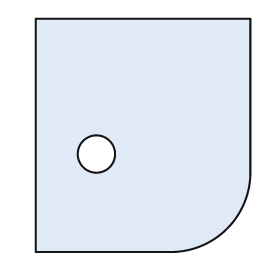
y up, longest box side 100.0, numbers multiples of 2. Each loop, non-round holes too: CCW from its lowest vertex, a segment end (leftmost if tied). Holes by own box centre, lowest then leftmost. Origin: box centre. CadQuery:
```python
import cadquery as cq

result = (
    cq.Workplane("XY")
    .moveTo(-46.0, -50.0)
    .lineTo(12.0, -50.0)
    .threePointArc((36.0, -40.0), (46.0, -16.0))
    .lineTo(46.0, 50.0)
    .lineTo(-46.0, 50.0)
    .close()
    .moveTo(-20.0, -8.0)
    .circle(8.0)
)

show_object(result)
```